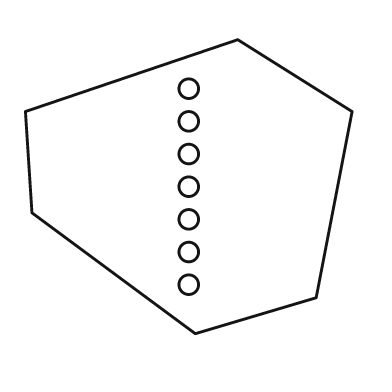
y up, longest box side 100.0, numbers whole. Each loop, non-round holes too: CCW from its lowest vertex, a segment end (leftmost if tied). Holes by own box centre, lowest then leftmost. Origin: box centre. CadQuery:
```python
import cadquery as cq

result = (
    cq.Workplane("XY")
    .moveTo(2.0, -45.0)
    .lineTo(39.0, -34.0)
    .lineTo(50.0, 23.0)
    .lineTo(15.0, 45.0)
    .lineTo(-50.0, 23.0)
    .lineTo(-48.0, -8.0)
    .close()
    .moveTo(0.0, -30.0)
    .circle(3.0)
    .moveTo(0.0, -20.0)
    .circle(3.0)
    .moveTo(0.0, -10.0)
    .circle(3.0)
    .moveTo(0.0, 0.0)
    .circle(3.0)
    .moveTo(0.0, 10.0)
    .circle(3.0)
    .moveTo(0.0, 20.0)
    .circle(3.0)
    .moveTo(0.0, 30.0)
    .circle(3.0)
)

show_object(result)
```